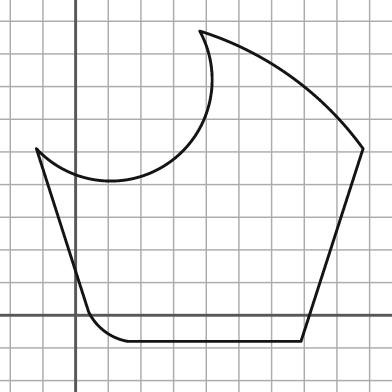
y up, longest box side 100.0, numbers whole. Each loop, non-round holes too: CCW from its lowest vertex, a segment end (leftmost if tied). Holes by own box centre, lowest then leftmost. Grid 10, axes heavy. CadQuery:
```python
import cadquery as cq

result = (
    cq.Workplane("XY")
    .moveTo(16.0, -8.0)
    .lineTo(69.0, -8.0)
    .lineTo(88.0, 51.0)
    .threePointArc((66.0, 73.0), (38.0, 87.0))
    .threePointArc((29.0, 47.0), (-12.0, 51.0))
    .lineTo(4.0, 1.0)
    .threePointArc((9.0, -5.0), (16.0, -8.0))
    .close()
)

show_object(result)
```